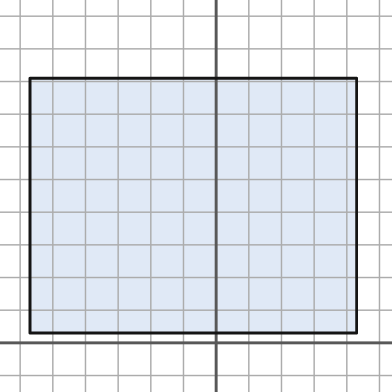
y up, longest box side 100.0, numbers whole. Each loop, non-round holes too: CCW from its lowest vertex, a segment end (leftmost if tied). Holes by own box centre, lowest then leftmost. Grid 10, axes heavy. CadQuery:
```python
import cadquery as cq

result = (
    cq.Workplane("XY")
    .moveTo(-57.0, 3.0)
    .lineTo(43.0, 3.0)
    .lineTo(43.0, 81.0)
    .lineTo(-57.0, 81.0)
    .close()
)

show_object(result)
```